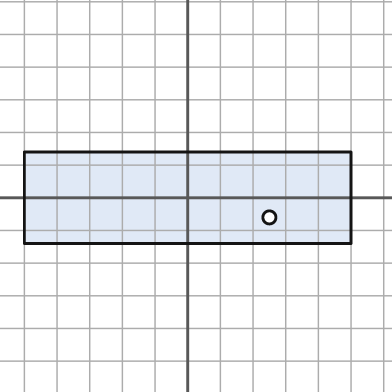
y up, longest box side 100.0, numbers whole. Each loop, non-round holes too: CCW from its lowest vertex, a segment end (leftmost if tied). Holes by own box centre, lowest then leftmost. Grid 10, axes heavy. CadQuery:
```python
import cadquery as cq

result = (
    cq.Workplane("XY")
    .moveTo(-50.0, -14.0)
    .lineTo(50.0, -14.0)
    .lineTo(50.0, 14.0)
    .lineTo(-50.0, 14.0)
    .close()
    .moveTo(25.0, -6.0)
    .circle(2.0)
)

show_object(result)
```